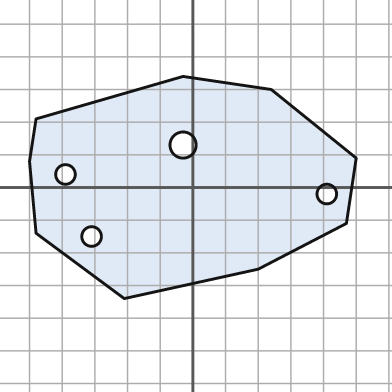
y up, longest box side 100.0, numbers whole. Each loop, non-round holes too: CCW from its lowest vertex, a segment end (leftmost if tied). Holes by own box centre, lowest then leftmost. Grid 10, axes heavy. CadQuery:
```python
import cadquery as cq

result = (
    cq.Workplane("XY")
    .moveTo(-21.0, -34.0)
    .lineTo(20.0, -25.0)
    .lineTo(47.0, -11.0)
    .lineTo(50.0, 9.0)
    .lineTo(24.0, 30.0)
    .lineTo(-3.0, 34.0)
    .lineTo(-48.0, 21.0)
    .lineTo(-50.0, 8.0)
    .lineTo(-48.0, -14.0)
    .close()
    .moveTo(-31.0, -15.0)
    .circle(3.0)
    .moveTo(41.0, -2.0)
    .circle(3.0)
    .moveTo(-39.0, 4.0)
    .circle(3.0)
    .moveTo(-3.0, 13.0)
    .circle(4.0)
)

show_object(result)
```